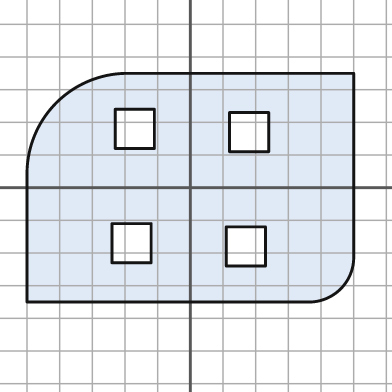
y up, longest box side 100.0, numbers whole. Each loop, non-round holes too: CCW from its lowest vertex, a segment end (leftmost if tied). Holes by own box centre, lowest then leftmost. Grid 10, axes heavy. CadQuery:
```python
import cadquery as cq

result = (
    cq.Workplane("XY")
    .moveTo(-50.0, -35.0)
    .lineTo(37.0, -35.0)
    .threePointArc((46.0, -31.0), (50.0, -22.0))
    .lineTo(50.0, 35.0)
    .lineTo(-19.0, 35.0)
    .threePointArc((-41.0, 26.0), (-50.0, 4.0))
    .close()
    .moveTo(11.0, -24.0)
    .lineTo(23.0, -24.0)
    .lineTo(23.0, -12.0)
    .lineTo(11.0, -12.0)
    .close()
    .moveTo(-24.0, -23.0)
    .lineTo(-12.0, -23.0)
    .lineTo(-12.0, -11.0)
    .lineTo(-24.0, -11.0)
    .close()
    .moveTo(12.0, 11.0)
    .lineTo(24.0, 11.0)
    .lineTo(24.0, 23.0)
    .lineTo(12.0, 23.0)
    .close()
    .moveTo(-23.0, 12.0)
    .lineTo(-11.0, 12.0)
    .lineTo(-11.0, 24.0)
    .lineTo(-23.0, 24.0)
    .close()
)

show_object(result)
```